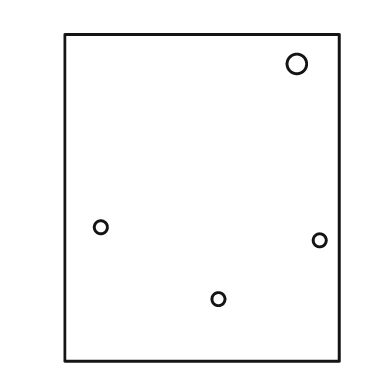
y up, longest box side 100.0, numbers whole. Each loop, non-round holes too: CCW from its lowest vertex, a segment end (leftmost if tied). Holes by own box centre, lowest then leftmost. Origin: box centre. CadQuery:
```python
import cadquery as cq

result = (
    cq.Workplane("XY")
    .moveTo(-42.0, -50.0)
    .lineTo(42.0, -50.0)
    .lineTo(42.0, 50.0)
    .lineTo(-42.0, 50.0)
    .close()
    .moveTo(5.0, -31.0)
    .circle(2.0)
    .moveTo(36.0, -13.0)
    .circle(2.0)
    .moveTo(-31.0, -9.0)
    .circle(2.0)
    .moveTo(29.0, 41.0)
    .circle(3.0)
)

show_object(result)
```